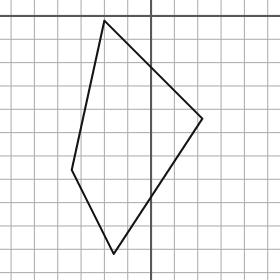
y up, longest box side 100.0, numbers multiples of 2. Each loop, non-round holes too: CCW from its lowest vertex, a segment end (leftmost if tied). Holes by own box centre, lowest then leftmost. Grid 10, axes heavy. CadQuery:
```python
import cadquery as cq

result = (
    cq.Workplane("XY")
    .moveTo(-16.0, -102.0)
    .lineTo(22.0, -44.0)
    .lineTo(-20.0, -2.0)
    .lineTo(-34.0, -66.0)
    .close()
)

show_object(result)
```